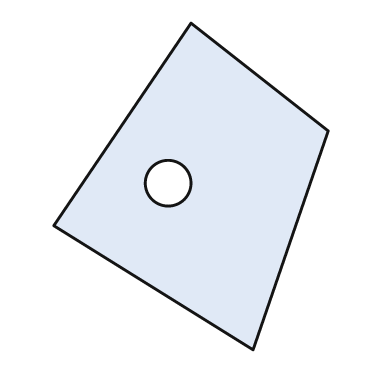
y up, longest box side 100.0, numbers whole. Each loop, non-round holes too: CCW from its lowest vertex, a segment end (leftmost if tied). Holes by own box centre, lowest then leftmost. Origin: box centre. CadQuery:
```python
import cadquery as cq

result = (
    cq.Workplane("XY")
    .moveTo(19.0, -50.0)
    .lineTo(42.0, 17.0)
    .lineTo(0.0, 50.0)
    .lineTo(-42.0, -12.0)
    .close()
    .moveTo(-7.0, 1.0)
    .circle(7.0)
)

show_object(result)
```